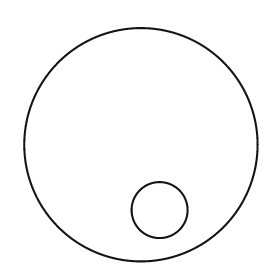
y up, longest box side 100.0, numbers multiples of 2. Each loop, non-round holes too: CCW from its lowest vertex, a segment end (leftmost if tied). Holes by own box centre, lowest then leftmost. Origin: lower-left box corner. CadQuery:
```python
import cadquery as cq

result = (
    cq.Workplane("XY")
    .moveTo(50.0, 50.0)
    .circle(50.0)
    .moveTo(58.0, 22.0)
    .circle(12.0)
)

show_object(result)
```